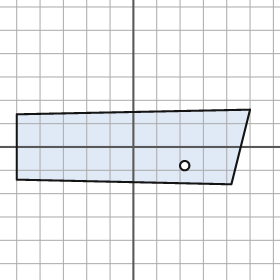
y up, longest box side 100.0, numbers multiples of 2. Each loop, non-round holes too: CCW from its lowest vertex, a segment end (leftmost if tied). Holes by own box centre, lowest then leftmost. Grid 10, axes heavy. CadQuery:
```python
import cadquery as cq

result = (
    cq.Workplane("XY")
    .moveTo(42.0, -16.0)
    .lineTo(50.0, 16.0)
    .lineTo(-50.0, 14.0)
    .lineTo(-50.0, -14.0)
    .close()
    .moveTo(22.0, -8.0)
    .circle(2.0)
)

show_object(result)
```